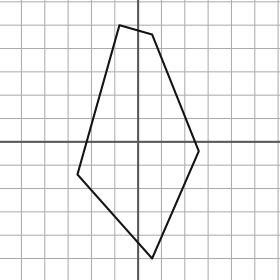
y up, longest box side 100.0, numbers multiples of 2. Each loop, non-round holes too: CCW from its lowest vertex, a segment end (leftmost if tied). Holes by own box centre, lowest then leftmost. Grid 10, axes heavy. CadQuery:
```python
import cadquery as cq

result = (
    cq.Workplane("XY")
    .moveTo(6.0, -50.0)
    .lineTo(26.0, -4.0)
    .lineTo(6.0, 46.0)
    .lineTo(-8.0, 50.0)
    .lineTo(-26.0, -14.0)
    .close()
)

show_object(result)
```